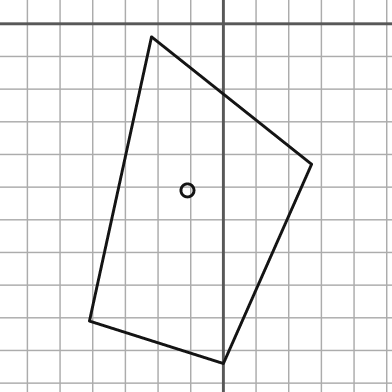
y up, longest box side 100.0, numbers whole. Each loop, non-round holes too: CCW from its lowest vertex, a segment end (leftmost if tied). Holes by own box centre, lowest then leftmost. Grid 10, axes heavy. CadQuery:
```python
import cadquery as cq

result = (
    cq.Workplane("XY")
    .moveTo(0.0, -104.0)
    .lineTo(27.0, -43.0)
    .lineTo(-22.0, -4.0)
    .lineTo(-41.0, -91.0)
    .close()
    .moveTo(-11.0, -51.0)
    .circle(2.0)
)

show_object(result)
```